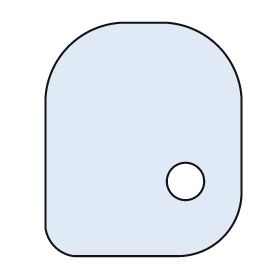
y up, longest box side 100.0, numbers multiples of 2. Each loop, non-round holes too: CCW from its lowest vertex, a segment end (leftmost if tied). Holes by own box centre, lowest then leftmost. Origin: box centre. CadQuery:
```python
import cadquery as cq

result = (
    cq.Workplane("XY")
    .moveTo(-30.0, -50.0)
    .lineTo(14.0, -50.0)
    .threePointArc((34.0, -42.0), (42.0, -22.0))
    .lineTo(42.0, 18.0)
    .threePointArc((32.0, 40.0), (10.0, 50.0))
    .lineTo(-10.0, 50.0)
    .threePointArc((-32.0, 40.0), (-42.0, 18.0))
    .lineTo(-42.0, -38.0)
    .threePointArc((-38.0, -46.0), (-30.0, -50.0))
    .close()
    .moveTo(18.0, -18.0)
    .circle(8.0)
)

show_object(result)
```